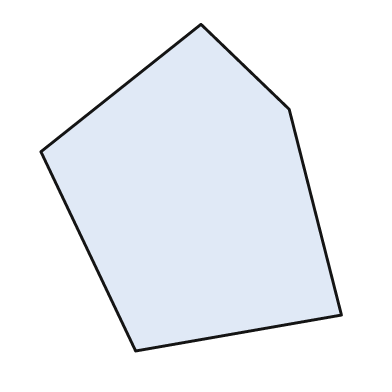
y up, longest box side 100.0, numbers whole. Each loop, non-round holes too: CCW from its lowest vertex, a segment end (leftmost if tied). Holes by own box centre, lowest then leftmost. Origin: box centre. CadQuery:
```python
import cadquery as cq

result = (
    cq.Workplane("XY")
    .moveTo(-17.0, -50.0)
    .lineTo(46.0, -39.0)
    .lineTo(30.0, 24.0)
    .lineTo(3.0, 50.0)
    .lineTo(-46.0, 11.0)
    .close()
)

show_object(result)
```